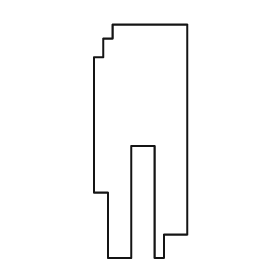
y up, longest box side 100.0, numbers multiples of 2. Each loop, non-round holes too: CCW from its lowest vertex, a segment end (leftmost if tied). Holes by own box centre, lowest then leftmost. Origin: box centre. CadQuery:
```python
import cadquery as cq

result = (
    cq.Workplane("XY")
    .moveTo(-14.0, -50.0)
    .lineTo(-4.0, -50.0)
    .lineTo(-4.0, -2.0)
    .lineTo(6.0, -2.0)
    .lineTo(6.0, -50.0)
    .lineTo(10.0, -50.0)
    .lineTo(10.0, -40.0)
    .lineTo(20.0, -40.0)
    .lineTo(20.0, 50.0)
    .lineTo(-12.0, 50.0)
    .lineTo(-12.0, 44.0)
    .lineTo(-16.0, 44.0)
    .lineTo(-16.0, 36.0)
    .lineTo(-20.0, 36.0)
    .lineTo(-20.0, -22.0)
    .lineTo(-14.0, -22.0)
    .close()
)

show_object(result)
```